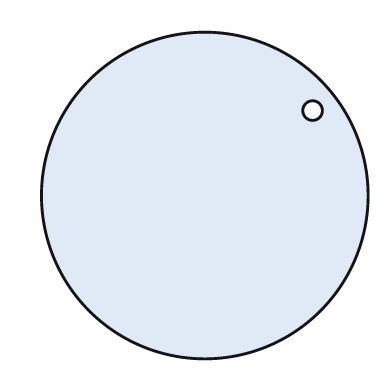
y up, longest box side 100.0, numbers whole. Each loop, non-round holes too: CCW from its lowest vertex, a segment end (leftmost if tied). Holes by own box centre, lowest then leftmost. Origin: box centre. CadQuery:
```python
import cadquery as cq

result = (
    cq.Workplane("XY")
    .moveTo(0.0, 0.0)
    .circle(50.0)
    .moveTo(33.0, 26.0)
    .circle(3.0)
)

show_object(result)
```